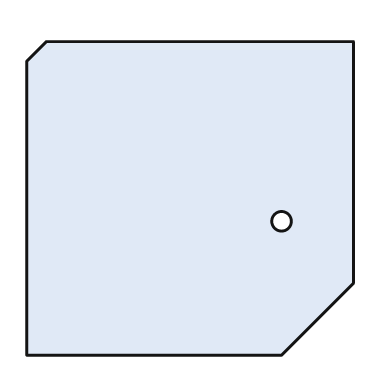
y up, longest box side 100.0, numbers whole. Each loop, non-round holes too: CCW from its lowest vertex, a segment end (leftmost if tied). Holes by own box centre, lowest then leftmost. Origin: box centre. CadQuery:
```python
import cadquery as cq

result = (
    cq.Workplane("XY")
    .moveTo(-50.0, -48.0)
    .lineTo(28.0, -48.0)
    .lineTo(50.0, -26.0)
    .lineTo(50.0, 48.0)
    .lineTo(-44.0, 48.0)
    .lineTo(-50.0, 42.0)
    .close()
    .moveTo(28.0, -7.0)
    .circle(3.0)
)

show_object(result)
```